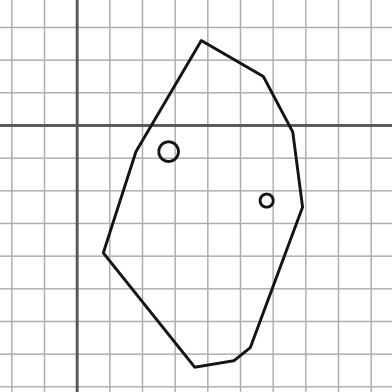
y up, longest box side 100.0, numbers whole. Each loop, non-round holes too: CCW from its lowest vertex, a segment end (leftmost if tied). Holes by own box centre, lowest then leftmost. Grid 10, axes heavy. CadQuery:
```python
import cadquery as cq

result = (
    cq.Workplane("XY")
    .moveTo(36.0, -74.0)
    .lineTo(48.0, -72.0)
    .lineTo(53.0, -68.0)
    .lineTo(69.0, -25.0)
    .lineTo(66.0, -2.0)
    .lineTo(57.0, 15.0)
    .lineTo(38.0, 26.0)
    .lineTo(18.0, -8.0)
    .lineTo(8.0, -39.0)
    .close()
    .moveTo(58.0, -23.0)
    .circle(2.0)
    .moveTo(28.0, -8.0)
    .circle(3.0)
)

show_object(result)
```